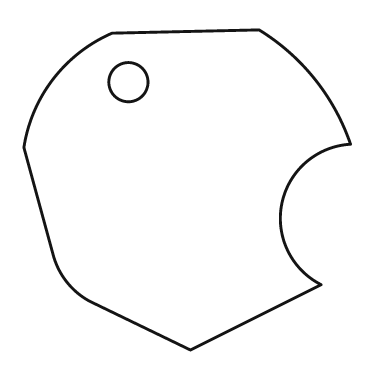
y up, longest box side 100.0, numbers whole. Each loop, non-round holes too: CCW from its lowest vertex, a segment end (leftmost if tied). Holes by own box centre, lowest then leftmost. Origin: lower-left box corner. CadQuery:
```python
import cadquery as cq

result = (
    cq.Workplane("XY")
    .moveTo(51.0, 0.0)
    .lineTo(91.0, 20.0)
    .threePointArc((79.0, 45.0), (100.0, 63.0))
    .threePointArc((89.0, 83.0), (72.0, 98.0))
    .lineTo(27.0, 97.0)
    .threePointArc((9.0, 83.0), (0.0, 62.0))
    .lineTo(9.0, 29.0)
    .threePointArc((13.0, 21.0), (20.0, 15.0))
    .close()
    .moveTo(32.0, 82.0)
    .circle(6.0)
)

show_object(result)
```